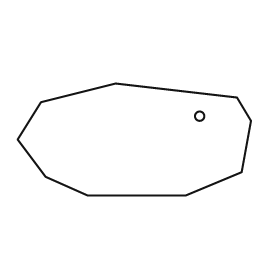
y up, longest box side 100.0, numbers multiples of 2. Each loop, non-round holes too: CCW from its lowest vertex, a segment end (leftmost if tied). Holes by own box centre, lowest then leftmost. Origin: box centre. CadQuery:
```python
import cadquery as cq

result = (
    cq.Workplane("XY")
    .moveTo(-20.0, -24.0)
    .lineTo(22.0, -24.0)
    .lineTo(46.0, -14.0)
    .lineTo(50.0, 8.0)
    .lineTo(44.0, 18.0)
    .lineTo(-8.0, 24.0)
    .lineTo(-40.0, 16.0)
    .lineTo(-50.0, 0.0)
    .lineTo(-38.0, -16.0)
    .close()
    .moveTo(28.0, 10.0)
    .circle(2.0)
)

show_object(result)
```